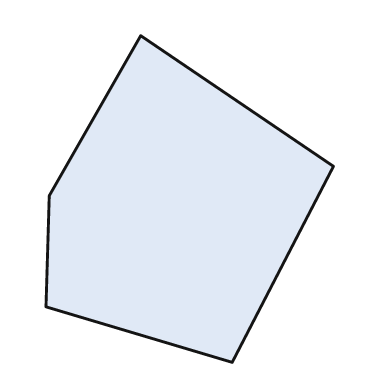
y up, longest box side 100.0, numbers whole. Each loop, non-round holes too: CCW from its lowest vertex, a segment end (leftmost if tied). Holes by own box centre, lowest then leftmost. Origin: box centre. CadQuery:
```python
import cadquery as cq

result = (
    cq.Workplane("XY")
    .moveTo(13.0, -50.0)
    .lineTo(44.0, 10.0)
    .lineTo(-15.0, 50.0)
    .lineTo(-43.0, 1.0)
    .lineTo(-44.0, -33.0)
    .close()
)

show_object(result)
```